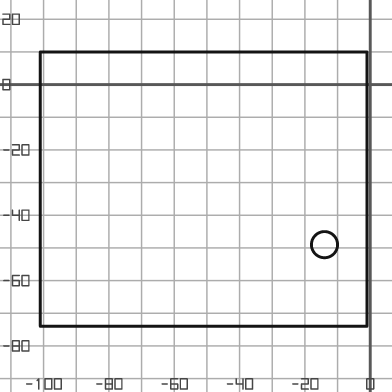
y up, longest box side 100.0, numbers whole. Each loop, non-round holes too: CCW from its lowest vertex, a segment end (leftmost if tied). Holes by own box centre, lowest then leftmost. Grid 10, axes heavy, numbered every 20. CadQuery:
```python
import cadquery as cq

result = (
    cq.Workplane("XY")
    .moveTo(-101.0, -74.0)
    .lineTo(-1.0, -74.0)
    .lineTo(-1.0, 10.0)
    .lineTo(-101.0, 10.0)
    .close()
    .moveTo(-14.0, -49.0)
    .circle(4.0)
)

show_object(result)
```